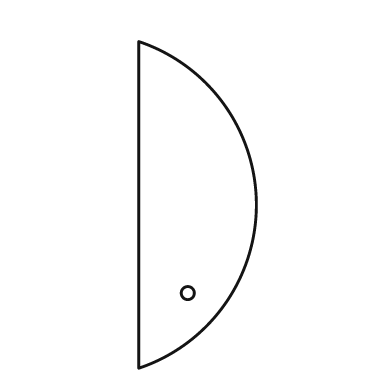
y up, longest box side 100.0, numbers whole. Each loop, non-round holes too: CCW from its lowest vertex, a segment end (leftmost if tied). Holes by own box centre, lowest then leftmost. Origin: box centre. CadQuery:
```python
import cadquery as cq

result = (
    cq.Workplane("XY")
    .moveTo(-18.0, -50.0)
    .threePointArc((18.0, 0.0), (-18.0, 50.0))
    .close()
    .moveTo(-3.0, -27.0)
    .circle(2.0)
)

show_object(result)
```